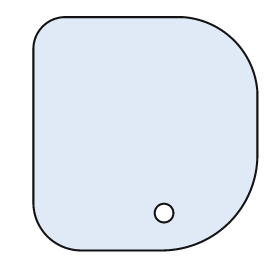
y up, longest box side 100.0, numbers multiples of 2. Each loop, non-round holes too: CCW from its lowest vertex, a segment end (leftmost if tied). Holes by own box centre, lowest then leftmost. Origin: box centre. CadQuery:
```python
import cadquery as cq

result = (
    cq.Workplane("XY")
    .moveTo(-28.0, -50.0)
    .lineTo(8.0, -50.0)
    .threePointArc((36.0, -38.0), (48.0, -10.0))
    .lineTo(48.0, 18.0)
    .threePointArc((38.0, 40.0), (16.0, 50.0))
    .lineTo(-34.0, 50.0)
    .threePointArc((-44.0, 46.0), (-48.0, 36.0))
    .lineTo(-48.0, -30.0)
    .threePointArc((-42.0, -44.0), (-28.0, -50.0))
    .close()
    .moveTo(8.0, -34.0)
    .circle(4.0)
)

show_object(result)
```